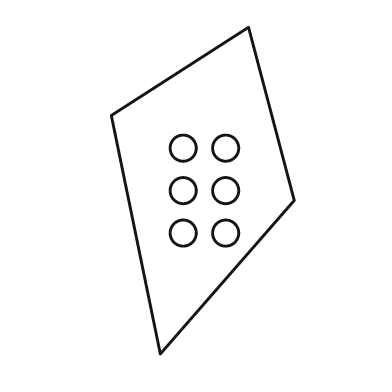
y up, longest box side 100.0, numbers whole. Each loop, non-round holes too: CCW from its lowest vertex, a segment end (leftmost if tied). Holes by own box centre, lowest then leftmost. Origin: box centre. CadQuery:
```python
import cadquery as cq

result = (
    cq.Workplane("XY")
    .moveTo(-13.0, -50.0)
    .lineTo(28.0, -3.0)
    .lineTo(14.0, 50.0)
    .lineTo(-28.0, 23.0)
    .close()
    .moveTo(-6.0, -13.0)
    .circle(4.0)
    .moveTo(7.0, -13.0)
    .circle(4.0)
    .moveTo(-6.0, 0.0)
    .circle(4.0)
    .moveTo(7.0, 0.0)
    .circle(4.0)
    .moveTo(-6.0, 13.0)
    .circle(4.0)
    .moveTo(7.0, 13.0)
    .circle(4.0)
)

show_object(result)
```